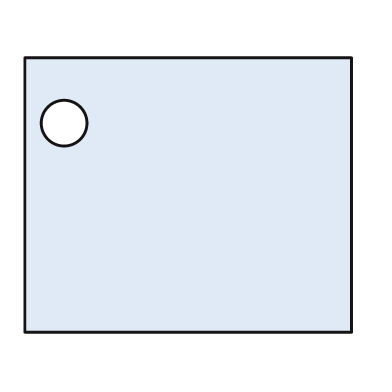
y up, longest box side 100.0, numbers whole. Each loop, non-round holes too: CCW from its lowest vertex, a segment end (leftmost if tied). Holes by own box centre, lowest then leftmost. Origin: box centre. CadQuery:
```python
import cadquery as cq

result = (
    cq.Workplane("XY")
    .moveTo(-50.0, -42.0)
    .lineTo(50.0, -42.0)
    .lineTo(50.0, 42.0)
    .lineTo(-50.0, 42.0)
    .close()
    .moveTo(-38.0, 22.0)
    .circle(7.0)
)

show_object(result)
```